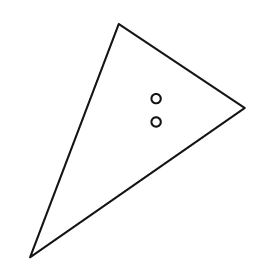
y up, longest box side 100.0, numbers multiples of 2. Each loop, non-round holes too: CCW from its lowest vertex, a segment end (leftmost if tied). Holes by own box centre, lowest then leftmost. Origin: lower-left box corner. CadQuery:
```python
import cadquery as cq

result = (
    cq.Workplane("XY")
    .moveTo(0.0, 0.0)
    .lineTo(92.0, 64.0)
    .lineTo(38.0, 100.0)
    .close()
    .moveTo(54.0, 58.0)
    .circle(2.0)
    .moveTo(54.0, 68.0)
    .circle(2.0)
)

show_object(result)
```